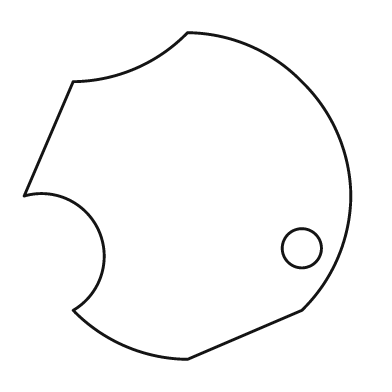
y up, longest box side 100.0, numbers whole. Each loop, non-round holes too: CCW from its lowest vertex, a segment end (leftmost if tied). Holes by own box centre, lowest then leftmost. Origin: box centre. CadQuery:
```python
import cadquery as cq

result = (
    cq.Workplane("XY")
    .moveTo(0.0, -50.0)
    .lineTo(35.0, -35.0)
    .threePointArc((46.0, -19.0), (50.0, 0.0))
    .threePointArc((46.0, 19.0), (35.0, 35.0))
    .threePointArc((19.0, 46.0), (0.0, 50.0))
    .threePointArc((-16.0, 39.0), (-35.0, 35.0))
    .lineTo(-50.0, 0.0)
    .threePointArc((-27.0, -11.0), (-35.0, -35.0))
    .threePointArc((-19.0, -46.0), (0.0, -50.0))
    .close()
    .moveTo(35.0, -16.0)
    .circle(6.0)
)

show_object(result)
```